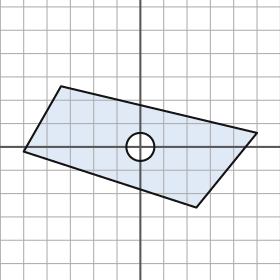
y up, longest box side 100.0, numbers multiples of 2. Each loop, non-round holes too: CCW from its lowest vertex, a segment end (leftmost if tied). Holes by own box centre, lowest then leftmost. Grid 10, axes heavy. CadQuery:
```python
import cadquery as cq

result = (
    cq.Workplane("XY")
    .moveTo(24.0, -26.0)
    .lineTo(50.0, 6.0)
    .lineTo(-34.0, 26.0)
    .lineTo(-50.0, -2.0)
    .close()
    .moveTo(0.0, 0.0)
    .circle(6.0)
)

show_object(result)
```